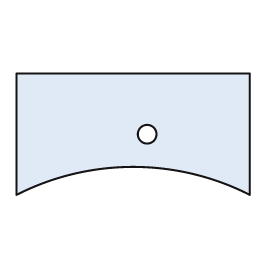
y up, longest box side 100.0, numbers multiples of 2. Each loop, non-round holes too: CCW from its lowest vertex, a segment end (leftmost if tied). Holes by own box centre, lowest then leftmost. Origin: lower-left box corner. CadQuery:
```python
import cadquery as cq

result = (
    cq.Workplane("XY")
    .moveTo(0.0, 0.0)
    .threePointArc((50.0, 12.0), (100.0, 0.0))
    .lineTo(100.0, 52.0)
    .lineTo(0.0, 52.0)
    .close()
    .moveTo(56.0, 26.0)
    .circle(4.0)
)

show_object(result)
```